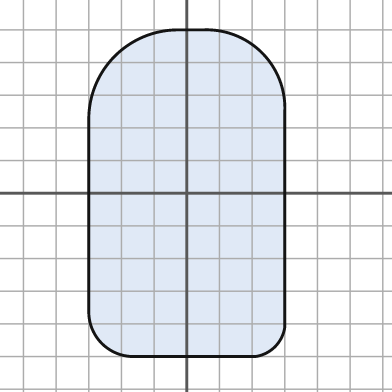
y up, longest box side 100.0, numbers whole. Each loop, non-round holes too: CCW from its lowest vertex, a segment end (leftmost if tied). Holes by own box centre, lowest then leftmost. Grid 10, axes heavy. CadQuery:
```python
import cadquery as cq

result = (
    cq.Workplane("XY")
    .moveTo(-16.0, -50.0)
    .lineTo(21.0, -50.0)
    .threePointArc((27.0, -47.0), (30.0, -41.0))
    .lineTo(30.0, 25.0)
    .threePointArc((23.0, 43.0), (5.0, 50.0))
    .lineTo(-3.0, 50.0)
    .threePointArc((-22.0, 42.0), (-30.0, 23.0))
    .lineTo(-30.0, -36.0)
    .threePointArc((-26.0, -46.0), (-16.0, -50.0))
    .close()
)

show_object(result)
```